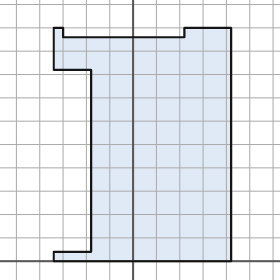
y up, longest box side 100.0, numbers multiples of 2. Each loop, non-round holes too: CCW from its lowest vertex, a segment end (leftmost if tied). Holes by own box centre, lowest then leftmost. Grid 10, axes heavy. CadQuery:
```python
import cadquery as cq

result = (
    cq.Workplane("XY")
    .moveTo(-34.0, 0.0)
    .lineTo(42.0, 0.0)
    .lineTo(42.0, 100.0)
    .lineTo(22.0, 100.0)
    .lineTo(22.0, 96.0)
    .lineTo(-30.0, 96.0)
    .lineTo(-30.0, 100.0)
    .lineTo(-34.0, 100.0)
    .lineTo(-34.0, 82.0)
    .lineTo(-18.0, 82.0)
    .lineTo(-18.0, 4.0)
    .lineTo(-34.0, 4.0)
    .close()
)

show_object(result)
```